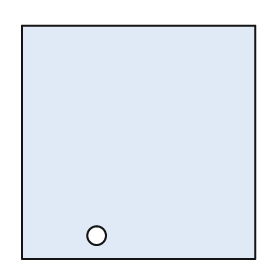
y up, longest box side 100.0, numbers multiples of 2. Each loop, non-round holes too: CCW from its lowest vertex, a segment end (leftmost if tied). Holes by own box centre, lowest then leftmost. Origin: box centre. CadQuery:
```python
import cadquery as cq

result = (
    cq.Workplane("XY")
    .moveTo(-50.0, -50.0)
    .lineTo(50.0, -50.0)
    .lineTo(50.0, 50.0)
    .lineTo(-50.0, 50.0)
    .close()
    .moveTo(-18.0, -40.0)
    .circle(4.0)
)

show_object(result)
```